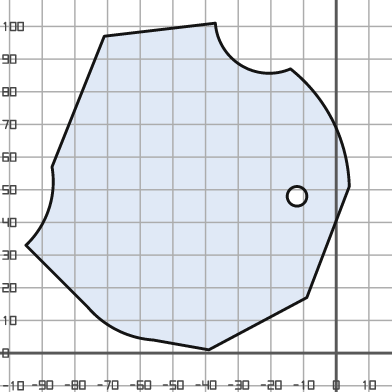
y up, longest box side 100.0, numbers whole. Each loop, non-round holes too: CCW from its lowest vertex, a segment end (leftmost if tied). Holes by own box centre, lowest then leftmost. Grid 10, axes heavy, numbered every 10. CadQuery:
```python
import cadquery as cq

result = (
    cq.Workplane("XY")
    .moveTo(-39.0, 1.0)
    .lineTo(-9.0, 17.0)
    .lineTo(4.0, 51.0)
    .threePointArc((-1.0, 71.0), (-14.0, 87.0))
    .threePointArc((-29.0, 88.0), (-37.0, 101.0))
    .lineTo(-71.0, 97.0)
    .lineTo(-87.0, 57.0)
    .threePointArc((-88.0, 44.0), (-95.0, 33.0))
    .lineTo(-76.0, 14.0)
    .threePointArc((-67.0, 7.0), (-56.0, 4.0))
    .close()
    .moveTo(-12.0, 48.0)
    .circle(3.0)
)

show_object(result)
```